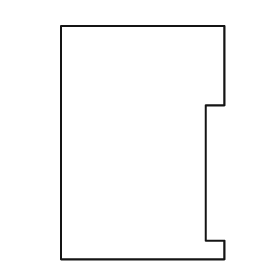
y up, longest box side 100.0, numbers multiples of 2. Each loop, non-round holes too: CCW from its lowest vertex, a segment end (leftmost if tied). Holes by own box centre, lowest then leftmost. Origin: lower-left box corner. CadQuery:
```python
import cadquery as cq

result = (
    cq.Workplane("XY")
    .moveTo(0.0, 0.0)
    .lineTo(70.0, 0.0)
    .lineTo(70.0, 8.0)
    .lineTo(62.0, 8.0)
    .lineTo(62.0, 66.0)
    .lineTo(70.0, 66.0)
    .lineTo(70.0, 100.0)
    .lineTo(0.0, 100.0)
    .close()
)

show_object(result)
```